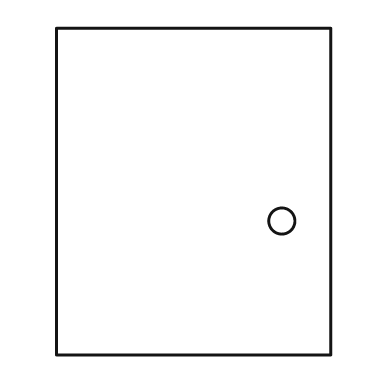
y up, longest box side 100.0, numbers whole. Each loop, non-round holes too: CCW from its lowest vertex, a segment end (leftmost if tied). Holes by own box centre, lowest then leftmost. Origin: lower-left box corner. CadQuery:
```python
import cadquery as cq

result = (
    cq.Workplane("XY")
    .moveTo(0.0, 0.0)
    .lineTo(84.0, 0.0)
    .lineTo(84.0, 100.0)
    .lineTo(0.0, 100.0)
    .close()
    .moveTo(69.0, 41.0)
    .circle(4.0)
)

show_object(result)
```